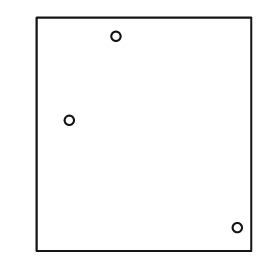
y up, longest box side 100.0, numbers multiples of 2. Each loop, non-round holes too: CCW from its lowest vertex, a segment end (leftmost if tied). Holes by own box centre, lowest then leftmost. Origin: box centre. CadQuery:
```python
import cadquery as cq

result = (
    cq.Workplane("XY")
    .moveTo(-46.0, -50.0)
    .lineTo(46.0, -50.0)
    .lineTo(46.0, 50.0)
    .lineTo(-46.0, 50.0)
    .close()
    .moveTo(40.0, -40.0)
    .circle(2.0)
    .moveTo(-32.0, 6.0)
    .circle(2.0)
    .moveTo(-12.0, 42.0)
    .circle(2.0)
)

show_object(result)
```